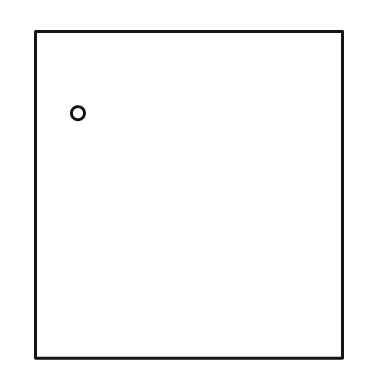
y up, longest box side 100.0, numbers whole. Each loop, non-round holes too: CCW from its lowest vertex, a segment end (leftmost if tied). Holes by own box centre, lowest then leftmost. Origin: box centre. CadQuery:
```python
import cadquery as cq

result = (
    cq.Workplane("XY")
    .moveTo(-47.0, -50.0)
    .lineTo(47.0, -50.0)
    .lineTo(47.0, 50.0)
    .lineTo(-47.0, 50.0)
    .close()
    .moveTo(-34.0, 25.0)
    .circle(2.0)
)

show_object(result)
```